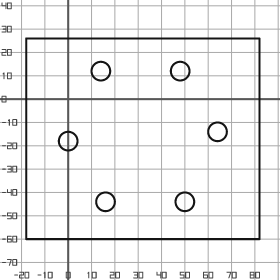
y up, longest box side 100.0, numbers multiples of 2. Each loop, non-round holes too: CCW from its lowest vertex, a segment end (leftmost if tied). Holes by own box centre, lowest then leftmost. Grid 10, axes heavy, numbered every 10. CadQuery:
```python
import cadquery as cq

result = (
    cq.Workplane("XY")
    .moveTo(-18.0, -60.0)
    .lineTo(82.0, -60.0)
    .lineTo(82.0, 26.0)
    .lineTo(-18.0, 26.0)
    .close()
    .moveTo(16.0, -44.0)
    .circle(4.0)
    .moveTo(50.0, -44.0)
    .circle(4.0)
    .moveTo(0.0, -18.0)
    .circle(4.0)
    .moveTo(64.0, -14.0)
    .circle(4.0)
    .moveTo(14.0, 12.0)
    .circle(4.0)
    .moveTo(48.0, 12.0)
    .circle(4.0)
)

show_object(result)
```